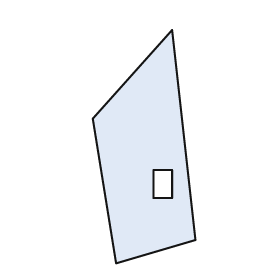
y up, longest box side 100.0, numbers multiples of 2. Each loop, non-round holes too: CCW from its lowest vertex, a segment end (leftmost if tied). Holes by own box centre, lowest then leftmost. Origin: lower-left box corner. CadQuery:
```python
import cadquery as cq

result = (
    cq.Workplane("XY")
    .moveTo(10.0, 0.0)
    .lineTo(44.0, 10.0)
    .lineTo(34.0, 100.0)
    .lineTo(0.0, 62.0)
    .close()
    .moveTo(26.0, 28.0)
    .lineTo(34.0, 28.0)
    .lineTo(34.0, 40.0)
    .lineTo(26.0, 40.0)
    .close()
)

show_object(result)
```